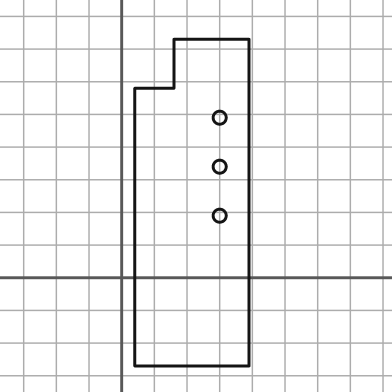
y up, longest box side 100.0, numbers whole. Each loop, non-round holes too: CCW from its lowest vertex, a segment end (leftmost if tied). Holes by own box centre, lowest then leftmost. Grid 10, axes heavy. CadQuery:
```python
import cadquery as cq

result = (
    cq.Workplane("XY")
    .moveTo(4.0, -27.0)
    .lineTo(39.0, -27.0)
    .lineTo(39.0, 73.0)
    .lineTo(16.0, 73.0)
    .lineTo(16.0, 58.0)
    .lineTo(4.0, 58.0)
    .close()
    .moveTo(30.0, 19.0)
    .circle(2.0)
    .moveTo(30.0, 34.0)
    .circle(2.0)
    .moveTo(30.0, 49.0)
    .circle(2.0)
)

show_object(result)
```